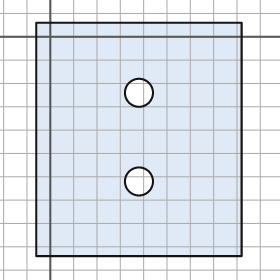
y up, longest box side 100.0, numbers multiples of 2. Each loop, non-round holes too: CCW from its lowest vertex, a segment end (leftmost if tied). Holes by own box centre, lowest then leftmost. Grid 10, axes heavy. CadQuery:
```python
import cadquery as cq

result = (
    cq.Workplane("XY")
    .moveTo(-6.0, -94.0)
    .lineTo(82.0, -94.0)
    .lineTo(82.0, 6.0)
    .lineTo(-6.0, 6.0)
    .close()
    .moveTo(38.0, -62.0)
    .circle(6.0)
    .moveTo(38.0, -24.0)
    .circle(6.0)
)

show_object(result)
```